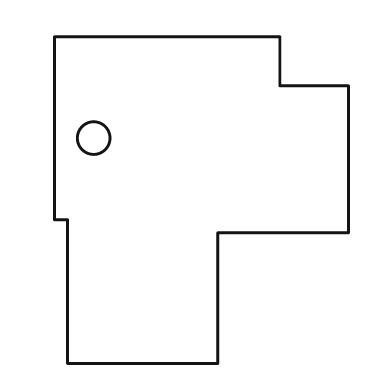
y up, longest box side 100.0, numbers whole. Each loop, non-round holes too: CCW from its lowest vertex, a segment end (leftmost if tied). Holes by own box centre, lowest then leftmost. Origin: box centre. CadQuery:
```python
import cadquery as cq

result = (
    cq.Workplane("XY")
    .moveTo(-41.0, -50.0)
    .lineTo(5.0, -50.0)
    .lineTo(5.0, -10.0)
    .lineTo(45.0, -10.0)
    .lineTo(45.0, 35.0)
    .lineTo(24.0, 35.0)
    .lineTo(24.0, 50.0)
    .lineTo(-45.0, 50.0)
    .lineTo(-45.0, -6.0)
    .lineTo(-41.0, -6.0)
    .close()
    .moveTo(-33.0, 19.0)
    .circle(5.0)
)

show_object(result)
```